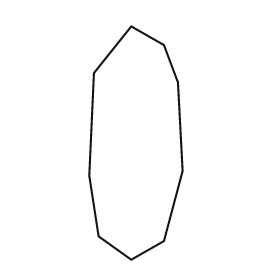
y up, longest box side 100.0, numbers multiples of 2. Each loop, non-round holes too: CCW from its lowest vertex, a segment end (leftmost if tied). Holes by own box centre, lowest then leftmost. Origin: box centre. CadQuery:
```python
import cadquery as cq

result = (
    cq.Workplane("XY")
    .moveTo(-2.0, -50.0)
    .lineTo(12.0, -42.0)
    .lineTo(20.0, -12.0)
    .lineTo(18.0, 26.0)
    .lineTo(12.0, 42.0)
    .lineTo(-2.0, 50.0)
    .lineTo(-18.0, 30.0)
    .lineTo(-20.0, -14.0)
    .lineTo(-16.0, -40.0)
    .close()
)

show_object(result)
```